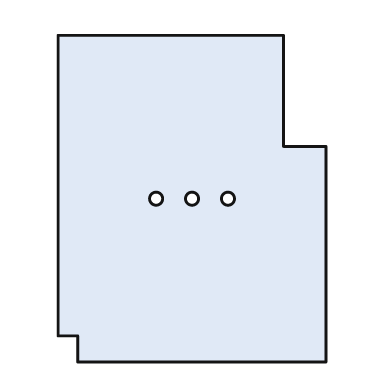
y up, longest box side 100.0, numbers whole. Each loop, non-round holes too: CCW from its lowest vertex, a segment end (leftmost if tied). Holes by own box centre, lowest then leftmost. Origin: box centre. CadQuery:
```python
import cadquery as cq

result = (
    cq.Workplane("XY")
    .moveTo(-35.0, -50.0)
    .lineTo(41.0, -50.0)
    .lineTo(41.0, 16.0)
    .lineTo(28.0, 16.0)
    .lineTo(28.0, 50.0)
    .lineTo(-41.0, 50.0)
    .lineTo(-41.0, -42.0)
    .lineTo(-35.0, -42.0)
    .close()
    .moveTo(-11.0, 0.0)
    .circle(2.0)
    .moveTo(0.0, 0.0)
    .circle(2.0)
    .moveTo(11.0, 0.0)
    .circle(2.0)
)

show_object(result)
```